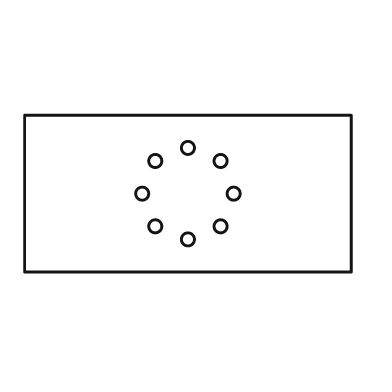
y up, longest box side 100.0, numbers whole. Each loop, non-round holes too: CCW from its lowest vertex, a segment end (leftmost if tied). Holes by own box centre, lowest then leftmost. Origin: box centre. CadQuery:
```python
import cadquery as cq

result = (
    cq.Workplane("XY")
    .moveTo(-50.0, -24.0)
    .lineTo(50.0, -24.0)
    .lineTo(50.0, 24.0)
    .lineTo(-50.0, 24.0)
    .close()
    .moveTo(0.0, -14.0)
    .circle(2.0)
    .moveTo(-10.0, -10.0)
    .circle(2.0)
    .moveTo(10.0, -10.0)
    .circle(2.0)
    .moveTo(-14.0, 0.0)
    .circle(2.0)
    .moveTo(14.0, 0.0)
    .circle(2.0)
    .moveTo(-10.0, 10.0)
    .circle(2.0)
    .moveTo(10.0, 10.0)
    .circle(2.0)
    .moveTo(0.0, 14.0)
    .circle(2.0)
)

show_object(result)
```